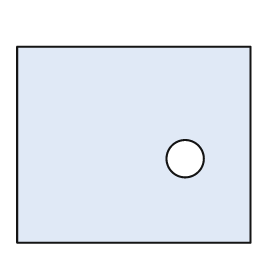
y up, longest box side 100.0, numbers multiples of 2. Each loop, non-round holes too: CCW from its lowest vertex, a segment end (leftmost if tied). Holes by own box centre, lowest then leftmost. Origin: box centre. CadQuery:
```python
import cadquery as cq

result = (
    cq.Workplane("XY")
    .moveTo(-50.0, -42.0)
    .lineTo(50.0, -42.0)
    .lineTo(50.0, 42.0)
    .lineTo(-50.0, 42.0)
    .close()
    .moveTo(22.0, -6.0)
    .circle(8.0)
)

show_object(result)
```